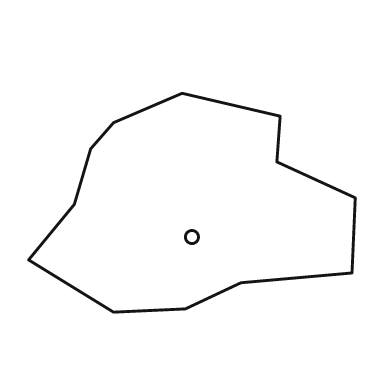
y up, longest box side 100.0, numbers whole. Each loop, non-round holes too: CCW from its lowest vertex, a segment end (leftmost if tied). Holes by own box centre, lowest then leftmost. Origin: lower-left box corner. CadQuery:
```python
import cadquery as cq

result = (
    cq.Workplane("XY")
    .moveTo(26.0, 0.0)
    .lineTo(48.0, 1.0)
    .lineTo(65.0, 9.0)
    .lineTo(99.0, 12.0)
    .lineTo(100.0, 35.0)
    .lineTo(76.0, 46.0)
    .lineTo(77.0, 60.0)
    .lineTo(47.0, 67.0)
    .lineTo(26.0, 58.0)
    .lineTo(19.0, 50.0)
    .lineTo(14.0, 33.0)
    .lineTo(0.0, 16.0)
    .close()
    .moveTo(50.0, 23.0)
    .circle(2.0)
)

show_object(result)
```